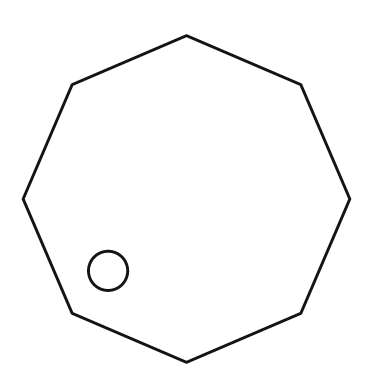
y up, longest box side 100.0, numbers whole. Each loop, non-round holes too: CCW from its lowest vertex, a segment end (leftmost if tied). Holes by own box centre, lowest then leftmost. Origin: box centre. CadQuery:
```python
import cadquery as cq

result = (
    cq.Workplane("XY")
    .moveTo(0.0, -50.0)
    .lineTo(35.0, -35.0)
    .lineTo(50.0, 0.0)
    .lineTo(35.0, 35.0)
    .lineTo(0.0, 50.0)
    .lineTo(-35.0, 35.0)
    .lineTo(-50.0, 0.0)
    .lineTo(-35.0, -35.0)
    .close()
    .moveTo(-24.0, -22.0)
    .circle(6.0)
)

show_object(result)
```